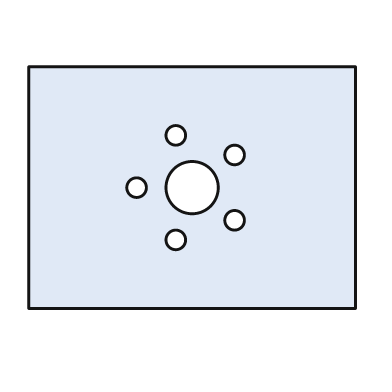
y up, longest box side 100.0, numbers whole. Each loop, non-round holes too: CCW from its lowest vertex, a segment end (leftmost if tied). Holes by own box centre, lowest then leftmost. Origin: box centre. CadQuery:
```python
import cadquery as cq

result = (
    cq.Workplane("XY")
    .moveTo(-50.0, -37.0)
    .lineTo(50.0, -37.0)
    .lineTo(50.0, 37.0)
    .lineTo(-50.0, 37.0)
    .close()
    .moveTo(-5.0, -16.0)
    .circle(3.0)
    .moveTo(13.0, -10.0)
    .circle(3.0)
    .moveTo(-17.0, 0.0)
    .circle(3.0)
    .moveTo(0.0, 0.0)
    .circle(8.0)
    .moveTo(13.0, 10.0)
    .circle(3.0)
    .moveTo(-5.0, 16.0)
    .circle(3.0)
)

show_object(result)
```